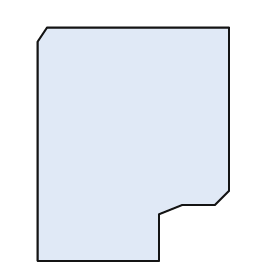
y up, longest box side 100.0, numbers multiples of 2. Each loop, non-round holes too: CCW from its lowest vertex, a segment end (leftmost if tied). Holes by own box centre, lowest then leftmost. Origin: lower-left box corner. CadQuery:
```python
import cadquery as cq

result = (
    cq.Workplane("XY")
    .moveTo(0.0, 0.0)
    .lineTo(52.0, 0.0)
    .lineTo(52.0, 20.0)
    .lineTo(62.0, 24.0)
    .lineTo(76.0, 24.0)
    .lineTo(82.0, 30.0)
    .lineTo(82.0, 100.0)
    .lineTo(4.0, 100.0)
    .lineTo(0.0, 94.0)
    .close()
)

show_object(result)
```